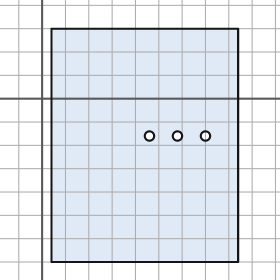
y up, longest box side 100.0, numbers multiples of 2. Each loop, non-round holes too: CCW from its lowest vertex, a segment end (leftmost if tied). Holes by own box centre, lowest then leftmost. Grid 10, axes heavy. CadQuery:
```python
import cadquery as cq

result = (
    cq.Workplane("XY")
    .moveTo(4.0, -70.0)
    .lineTo(84.0, -70.0)
    .lineTo(84.0, 30.0)
    .lineTo(4.0, 30.0)
    .close()
    .moveTo(46.0, -16.0)
    .circle(2.0)
    .moveTo(58.0, -16.0)
    .circle(2.0)
    .moveTo(70.0, -16.0)
    .circle(2.0)
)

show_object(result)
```